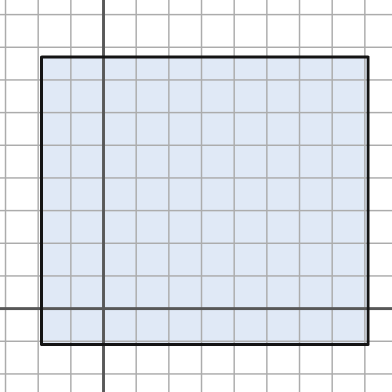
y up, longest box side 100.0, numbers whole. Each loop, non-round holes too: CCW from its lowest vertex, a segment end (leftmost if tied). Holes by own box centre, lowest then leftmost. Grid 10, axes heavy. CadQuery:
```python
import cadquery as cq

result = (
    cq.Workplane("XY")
    .moveTo(-19.0, -11.0)
    .lineTo(81.0, -11.0)
    .lineTo(81.0, 77.0)
    .lineTo(-19.0, 77.0)
    .close()
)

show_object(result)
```